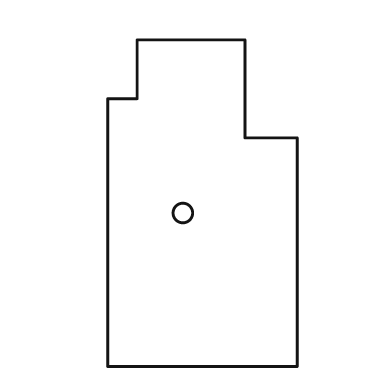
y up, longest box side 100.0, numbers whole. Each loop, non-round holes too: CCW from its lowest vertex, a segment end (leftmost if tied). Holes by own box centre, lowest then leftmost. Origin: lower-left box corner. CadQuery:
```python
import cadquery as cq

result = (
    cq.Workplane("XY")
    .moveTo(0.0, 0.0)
    .lineTo(58.0, 0.0)
    .lineTo(58.0, 70.0)
    .lineTo(42.0, 70.0)
    .lineTo(42.0, 100.0)
    .lineTo(9.0, 100.0)
    .lineTo(9.0, 82.0)
    .lineTo(0.0, 82.0)
    .close()
    .moveTo(23.0, 47.0)
    .circle(3.0)
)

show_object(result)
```